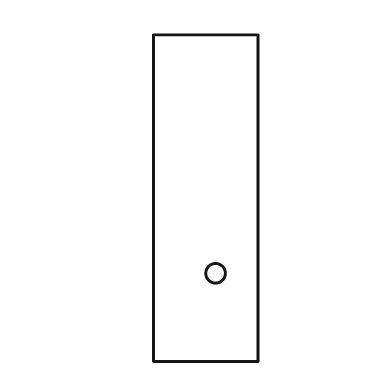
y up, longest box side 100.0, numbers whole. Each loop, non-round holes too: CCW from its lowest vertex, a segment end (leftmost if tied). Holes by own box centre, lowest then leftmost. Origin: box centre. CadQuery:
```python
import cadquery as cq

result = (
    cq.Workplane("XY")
    .moveTo(-16.0, -50.0)
    .lineTo(16.0, -50.0)
    .lineTo(16.0, 50.0)
    .lineTo(-16.0, 50.0)
    .close()
    .moveTo(3.0, -23.0)
    .circle(3.0)
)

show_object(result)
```